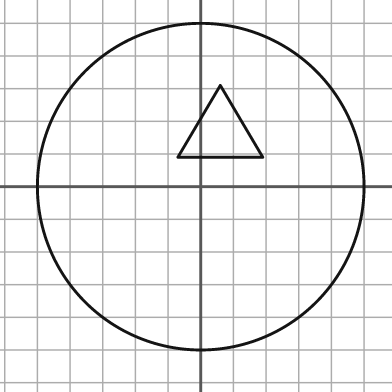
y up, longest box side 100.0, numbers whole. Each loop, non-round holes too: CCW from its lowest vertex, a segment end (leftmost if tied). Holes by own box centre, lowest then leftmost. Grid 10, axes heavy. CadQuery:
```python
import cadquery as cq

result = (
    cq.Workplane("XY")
    .moveTo(0.0, 0.0)
    .circle(50.0)
    .moveTo(-7.0, 9.0)
    .lineTo(19.0, 9.0)
    .lineTo(6.0, 31.0)
    .close()
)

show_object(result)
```